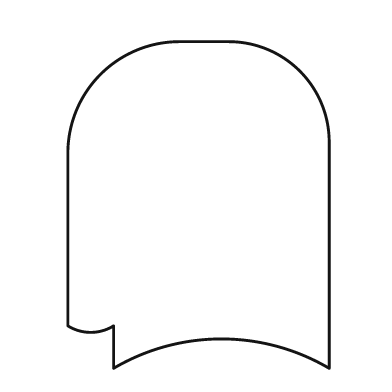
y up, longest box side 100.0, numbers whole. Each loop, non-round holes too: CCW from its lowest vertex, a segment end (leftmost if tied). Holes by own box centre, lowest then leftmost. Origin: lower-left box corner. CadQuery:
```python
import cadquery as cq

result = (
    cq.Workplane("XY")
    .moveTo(14.0, 0.0)
    .threePointArc((47.0, 9.0), (80.0, 0.0))
    .lineTo(80.0, 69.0)
    .threePointArc((71.0, 91.0), (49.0, 100.0))
    .lineTo(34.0, 100.0)
    .threePointArc((10.0, 90.0), (0.0, 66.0))
    .lineTo(0.0, 13.0)
    .threePointArc((7.0, 11.0), (14.0, 13.0))
    .close()
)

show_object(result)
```